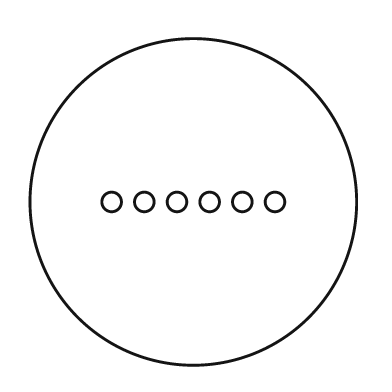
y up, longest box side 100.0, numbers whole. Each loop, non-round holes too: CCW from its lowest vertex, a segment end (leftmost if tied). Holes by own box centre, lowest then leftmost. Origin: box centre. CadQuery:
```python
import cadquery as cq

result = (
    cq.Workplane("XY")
    .moveTo(0.0, 0.0)
    .circle(50.0)
    .moveTo(-25.0, 0.0)
    .circle(3.0)
    .moveTo(-15.0, 0.0)
    .circle(3.0)
    .moveTo(-5.0, 0.0)
    .circle(3.0)
    .moveTo(5.0, 0.0)
    .circle(3.0)
    .moveTo(15.0, 0.0)
    .circle(3.0)
    .moveTo(25.0, 0.0)
    .circle(3.0)
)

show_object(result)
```